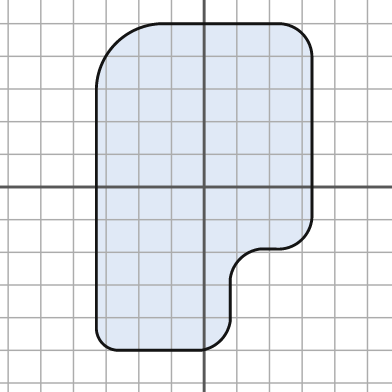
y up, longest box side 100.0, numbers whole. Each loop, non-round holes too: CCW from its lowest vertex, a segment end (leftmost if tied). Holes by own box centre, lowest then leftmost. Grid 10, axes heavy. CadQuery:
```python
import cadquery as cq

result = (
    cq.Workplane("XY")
    .moveTo(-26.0, -50.0)
    .lineTo(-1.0, -50.0)
    .threePointArc((5.0, -47.0), (8.0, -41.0))
    .lineTo(8.0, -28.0)
    .threePointArc((11.0, -22.0), (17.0, -19.0))
    .lineTo(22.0, -19.0)
    .threePointArc((30.0, -16.0), (33.0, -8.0))
    .lineTo(33.0, 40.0)
    .threePointArc((30.0, 47.0), (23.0, 50.0))
    .lineTo(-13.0, 50.0)
    .threePointArc((-27.0, 44.0), (-33.0, 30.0))
    .lineTo(-33.0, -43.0)
    .threePointArc((-31.0, -48.0), (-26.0, -50.0))
    .close()
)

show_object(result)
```